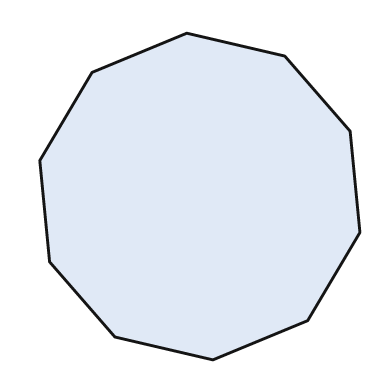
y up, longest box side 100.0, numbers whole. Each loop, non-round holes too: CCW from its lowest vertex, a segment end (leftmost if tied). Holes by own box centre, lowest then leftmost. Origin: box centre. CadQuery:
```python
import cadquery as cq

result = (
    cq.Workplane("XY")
    .moveTo(4.0, -50.0)
    .lineTo(33.0, -38.0)
    .lineTo(49.0, -11.0)
    .lineTo(46.0, 20.0)
    .lineTo(26.0, 43.0)
    .lineTo(-4.0, 50.0)
    .lineTo(-33.0, 38.0)
    .lineTo(-49.0, 11.0)
    .lineTo(-46.0, -20.0)
    .lineTo(-26.0, -43.0)
    .close()
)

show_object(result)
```